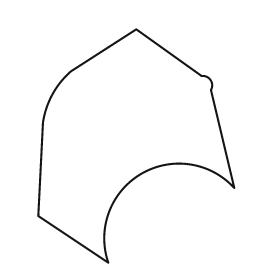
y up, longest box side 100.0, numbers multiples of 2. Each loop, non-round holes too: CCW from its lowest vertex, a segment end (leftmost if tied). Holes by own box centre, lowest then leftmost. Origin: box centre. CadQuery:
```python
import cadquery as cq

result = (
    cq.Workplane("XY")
    .moveTo(-12.0, -50.0)
    .threePointArc((2.0, -12.0), (42.0, -18.0))
    .lineTo(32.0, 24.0)
    .threePointArc((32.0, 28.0), (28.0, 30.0))
    .lineTo(0.0, 50.0)
    .lineTo(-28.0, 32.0)
    .threePointArc((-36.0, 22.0), (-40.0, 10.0))
    .lineTo(-42.0, -30.0)
    .close()
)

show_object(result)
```